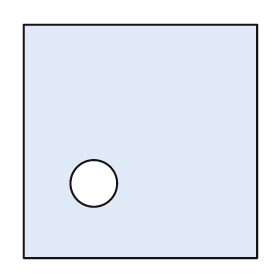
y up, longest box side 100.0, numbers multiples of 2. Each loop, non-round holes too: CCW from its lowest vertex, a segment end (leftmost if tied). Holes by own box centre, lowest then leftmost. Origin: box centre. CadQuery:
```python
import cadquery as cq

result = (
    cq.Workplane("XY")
    .moveTo(-50.0, -50.0)
    .lineTo(50.0, -50.0)
    .lineTo(50.0, 50.0)
    .lineTo(-50.0, 50.0)
    .close()
    .moveTo(-20.0, -18.0)
    .circle(10.0)
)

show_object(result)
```